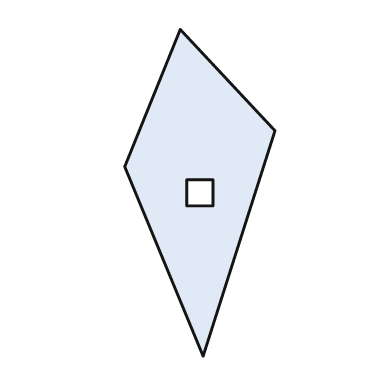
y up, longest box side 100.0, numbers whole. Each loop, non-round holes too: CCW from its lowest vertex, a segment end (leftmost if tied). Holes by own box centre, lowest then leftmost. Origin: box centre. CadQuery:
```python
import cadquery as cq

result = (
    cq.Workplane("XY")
    .moveTo(1.0, -50.0)
    .lineTo(23.0, 19.0)
    .lineTo(-6.0, 50.0)
    .lineTo(-23.0, 8.0)
    .close()
    .moveTo(-4.0, -4.0)
    .lineTo(4.0, -4.0)
    .lineTo(4.0, 4.0)
    .lineTo(-4.0, 4.0)
    .close()
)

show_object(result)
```